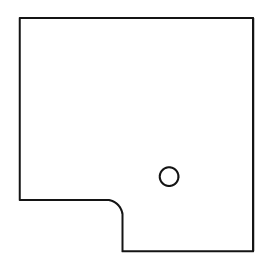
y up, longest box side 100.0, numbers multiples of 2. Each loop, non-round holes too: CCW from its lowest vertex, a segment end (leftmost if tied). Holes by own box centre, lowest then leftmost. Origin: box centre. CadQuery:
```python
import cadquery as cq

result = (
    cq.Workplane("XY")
    .moveTo(-6.0, -50.0)
    .lineTo(50.0, -50.0)
    .lineTo(50.0, 50.0)
    .lineTo(-50.0, 50.0)
    .lineTo(-50.0, -28.0)
    .lineTo(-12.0, -28.0)
    .threePointArc((-8.0, -30.0), (-6.0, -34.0))
    .close()
    .moveTo(14.0, -18.0)
    .circle(4.0)
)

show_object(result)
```